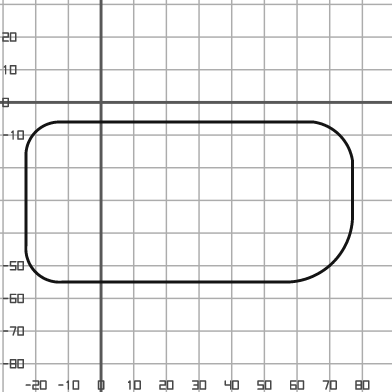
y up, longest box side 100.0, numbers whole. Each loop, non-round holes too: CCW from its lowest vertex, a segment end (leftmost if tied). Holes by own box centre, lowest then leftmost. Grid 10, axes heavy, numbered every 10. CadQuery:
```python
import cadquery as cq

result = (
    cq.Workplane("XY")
    .moveTo(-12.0, -55.0)
    .lineTo(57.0, -55.0)
    .threePointArc((71.0, -49.0), (77.0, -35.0))
    .lineTo(77.0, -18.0)
    .threePointArc((73.0, -10.0), (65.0, -6.0))
    .lineTo(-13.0, -6.0)
    .threePointArc((-20.0, -9.0), (-23.0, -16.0))
    .lineTo(-23.0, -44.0)
    .threePointArc((-20.0, -52.0), (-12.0, -55.0))
    .close()
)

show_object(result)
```